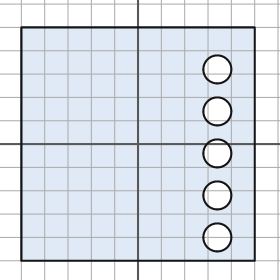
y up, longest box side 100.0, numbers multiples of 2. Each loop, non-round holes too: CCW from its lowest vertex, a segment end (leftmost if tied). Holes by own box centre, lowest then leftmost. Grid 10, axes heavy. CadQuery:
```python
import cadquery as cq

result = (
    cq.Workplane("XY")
    .moveTo(-50.0, -50.0)
    .lineTo(50.0, -50.0)
    .lineTo(50.0, 50.0)
    .lineTo(-50.0, 50.0)
    .close()
    .moveTo(34.0, -40.0)
    .circle(6.0)
    .moveTo(34.0, -22.0)
    .circle(6.0)
    .moveTo(34.0, -4.0)
    .circle(6.0)
    .moveTo(34.0, 14.0)
    .circle(6.0)
    .moveTo(34.0, 32.0)
    .circle(6.0)
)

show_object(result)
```